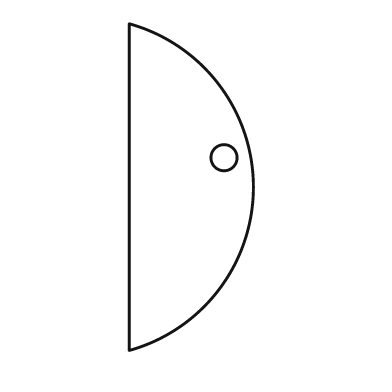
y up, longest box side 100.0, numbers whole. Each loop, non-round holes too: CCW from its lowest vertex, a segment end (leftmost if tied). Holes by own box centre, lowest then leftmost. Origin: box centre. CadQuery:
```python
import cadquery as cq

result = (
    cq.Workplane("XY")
    .moveTo(-19.0, -50.0)
    .threePointArc((19.0, 0.0), (-19.0, 50.0))
    .close()
    .moveTo(10.0, 9.0)
    .circle(4.0)
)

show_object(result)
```